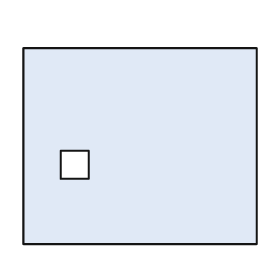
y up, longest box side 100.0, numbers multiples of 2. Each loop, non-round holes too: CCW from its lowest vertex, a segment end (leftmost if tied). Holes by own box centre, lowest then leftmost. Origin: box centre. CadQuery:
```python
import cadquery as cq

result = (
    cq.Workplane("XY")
    .moveTo(-50.0, -42.0)
    .lineTo(50.0, -42.0)
    .lineTo(50.0, 42.0)
    .lineTo(-50.0, 42.0)
    .close()
    .moveTo(-34.0, -14.0)
    .lineTo(-22.0, -14.0)
    .lineTo(-22.0, -2.0)
    .lineTo(-34.0, -2.0)
    .close()
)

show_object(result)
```